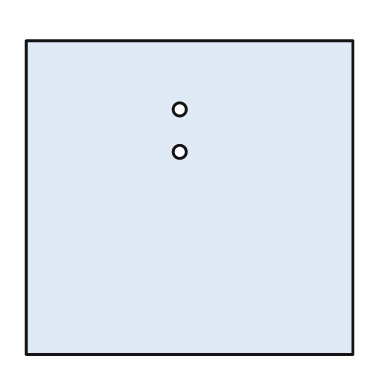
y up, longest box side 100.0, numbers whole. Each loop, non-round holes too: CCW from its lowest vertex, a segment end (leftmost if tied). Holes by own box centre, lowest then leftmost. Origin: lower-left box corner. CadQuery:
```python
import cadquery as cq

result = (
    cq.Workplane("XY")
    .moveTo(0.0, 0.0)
    .lineTo(100.0, 0.0)
    .lineTo(100.0, 96.0)
    .lineTo(0.0, 96.0)
    .close()
    .moveTo(47.0, 62.0)
    .circle(2.0)
    .moveTo(47.0, 75.0)
    .circle(2.0)
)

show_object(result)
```